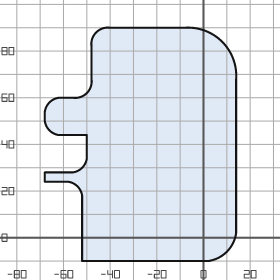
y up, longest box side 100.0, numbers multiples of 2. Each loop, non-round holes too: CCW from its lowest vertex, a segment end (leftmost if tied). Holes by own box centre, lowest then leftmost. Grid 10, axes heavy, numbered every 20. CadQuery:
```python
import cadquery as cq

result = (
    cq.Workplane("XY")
    .moveTo(-52.0, -10.0)
    .lineTo(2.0, -10.0)
    .threePointArc((10.0, -6.0), (14.0, 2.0))
    .lineTo(14.0, 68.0)
    .threePointArc((8.0, 84.0), (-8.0, 90.0))
    .lineTo(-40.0, 90.0)
    .threePointArc((-46.0, 88.0), (-48.0, 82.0))
    .lineTo(-48.0, 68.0)
    .threePointArc((-50.0, 62.0), (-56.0, 60.0))
    .lineTo(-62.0, 60.0)
    .threePointArc((-66.0, 58.0), (-68.0, 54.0))
    .lineTo(-68.0, 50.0)
    .threePointArc((-66.0, 46.0), (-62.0, 44.0))
    .lineTo(-50.0, 44.0)
    .lineTo(-50.0, 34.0)
    .threePointArc((-52.0, 30.0), (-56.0, 28.0))
    .lineTo(-68.0, 28.0)
    .lineTo(-68.0, 24.0)
    .lineTo(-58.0, 24.0)
    .threePointArc((-54.0, 22.0), (-52.0, 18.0))
    .close()
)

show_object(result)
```